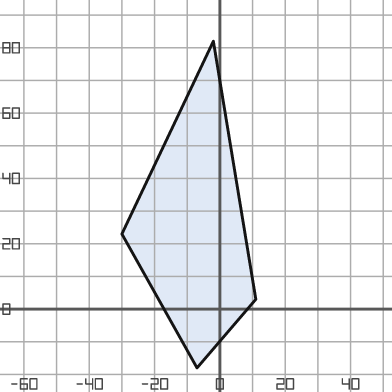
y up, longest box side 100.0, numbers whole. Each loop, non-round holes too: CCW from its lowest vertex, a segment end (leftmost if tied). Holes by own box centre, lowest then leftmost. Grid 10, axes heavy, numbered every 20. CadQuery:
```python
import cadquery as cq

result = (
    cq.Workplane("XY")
    .moveTo(-7.0, -18.0)
    .lineTo(11.0, 3.0)
    .lineTo(-2.0, 82.0)
    .lineTo(-30.0, 23.0)
    .close()
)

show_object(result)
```